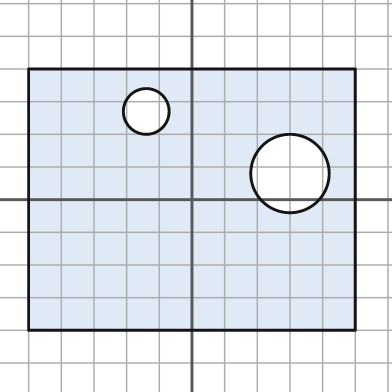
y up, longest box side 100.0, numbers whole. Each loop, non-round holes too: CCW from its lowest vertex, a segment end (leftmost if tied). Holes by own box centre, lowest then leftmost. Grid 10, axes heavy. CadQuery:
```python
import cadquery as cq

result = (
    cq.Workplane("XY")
    .moveTo(-50.0, -40.0)
    .lineTo(50.0, -40.0)
    .lineTo(50.0, 40.0)
    .lineTo(-50.0, 40.0)
    .close()
    .moveTo(30.0, 8.0)
    .circle(12.0)
    .moveTo(-14.0, 27.0)
    .circle(7.0)
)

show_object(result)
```